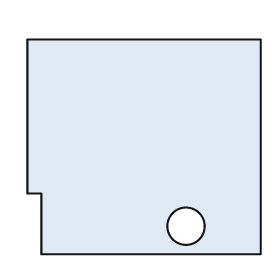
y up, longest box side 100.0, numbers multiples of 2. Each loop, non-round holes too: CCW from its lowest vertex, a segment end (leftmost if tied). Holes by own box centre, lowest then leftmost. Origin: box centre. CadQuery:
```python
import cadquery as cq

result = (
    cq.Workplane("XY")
    .moveTo(-44.0, -46.0)
    .lineTo(50.0, -46.0)
    .lineTo(50.0, 46.0)
    .lineTo(-50.0, 46.0)
    .lineTo(-50.0, -20.0)
    .lineTo(-44.0, -20.0)
    .close()
    .moveTo(18.0, -34.0)
    .circle(8.0)
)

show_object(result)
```